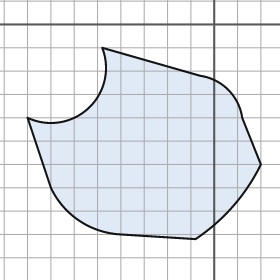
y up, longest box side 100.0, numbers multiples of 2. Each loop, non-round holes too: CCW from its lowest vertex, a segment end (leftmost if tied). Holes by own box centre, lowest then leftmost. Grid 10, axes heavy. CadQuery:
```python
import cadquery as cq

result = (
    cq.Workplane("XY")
    .moveTo(-8.0, -92.0)
    .threePointArc((8.0, -78.0), (20.0, -60.0))
    .lineTo(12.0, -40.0)
    .threePointArc((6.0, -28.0), (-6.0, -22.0))
    .lineTo(-48.0, -10.0)
    .threePointArc((-54.0, -36.0), (-80.0, -40.0))
    .lineTo(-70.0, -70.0)
    .threePointArc((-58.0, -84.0), (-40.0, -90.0))
    .close()
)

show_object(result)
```